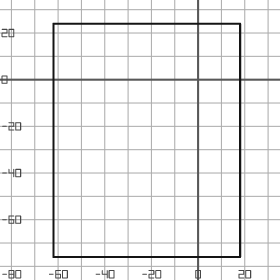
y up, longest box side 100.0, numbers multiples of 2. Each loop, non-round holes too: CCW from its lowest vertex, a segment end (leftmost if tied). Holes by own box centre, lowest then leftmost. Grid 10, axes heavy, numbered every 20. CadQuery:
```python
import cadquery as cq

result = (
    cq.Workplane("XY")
    .moveTo(-62.0, -76.0)
    .lineTo(18.0, -76.0)
    .lineTo(18.0, 24.0)
    .lineTo(-62.0, 24.0)
    .close()
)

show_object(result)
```